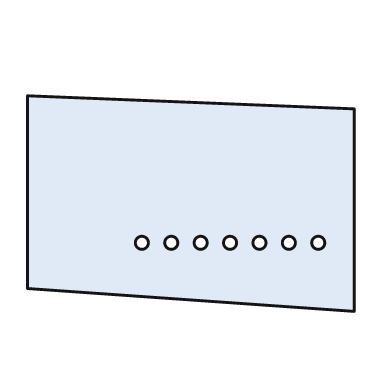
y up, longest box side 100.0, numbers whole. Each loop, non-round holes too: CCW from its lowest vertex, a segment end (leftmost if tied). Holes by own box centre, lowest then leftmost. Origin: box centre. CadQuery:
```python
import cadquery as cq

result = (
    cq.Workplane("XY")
    .moveTo(50.0, -33.0)
    .lineTo(50.0, 29.0)
    .lineTo(-50.0, 33.0)
    .lineTo(-50.0, -26.0)
    .close()
    .moveTo(-15.0, -12.0)
    .circle(2.0)
    .moveTo(-6.0, -12.0)
    .circle(2.0)
    .moveTo(3.0, -12.0)
    .circle(2.0)
    .moveTo(12.0, -12.0)
    .circle(2.0)
    .moveTo(21.0, -12.0)
    .circle(2.0)
    .moveTo(30.0, -12.0)
    .circle(2.0)
    .moveTo(39.0, -12.0)
    .circle(2.0)
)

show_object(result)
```